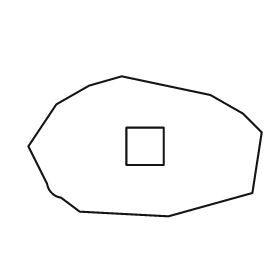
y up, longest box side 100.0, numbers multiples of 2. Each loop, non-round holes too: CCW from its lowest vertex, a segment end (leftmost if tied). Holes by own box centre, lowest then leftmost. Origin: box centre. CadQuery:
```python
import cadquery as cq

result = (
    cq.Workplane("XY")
    .moveTo(10.0, -30.0)
    .lineTo(46.0, -20.0)
    .lineTo(50.0, 6.0)
    .lineTo(42.0, 14.0)
    .lineTo(28.0, 22.0)
    .lineTo(-10.0, 30.0)
    .lineTo(-24.0, 26.0)
    .lineTo(-38.0, 18.0)
    .lineTo(-50.0, 0.0)
    .lineTo(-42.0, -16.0)
    .threePointArc((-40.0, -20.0), (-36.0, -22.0))
    .lineTo(-28.0, -28.0)
    .close()
    .moveTo(-8.0, -8.0)
    .lineTo(8.0, -8.0)
    .lineTo(8.0, 8.0)
    .lineTo(-8.0, 8.0)
    .close()
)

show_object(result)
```